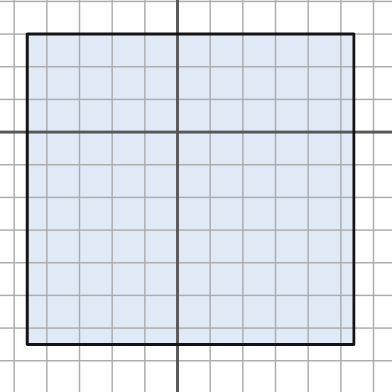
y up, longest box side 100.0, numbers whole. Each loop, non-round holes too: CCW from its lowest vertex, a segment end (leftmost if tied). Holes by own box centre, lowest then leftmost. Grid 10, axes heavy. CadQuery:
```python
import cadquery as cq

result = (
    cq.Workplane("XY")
    .moveTo(-46.0, -65.0)
    .lineTo(54.0, -65.0)
    .lineTo(54.0, 30.0)
    .lineTo(-46.0, 30.0)
    .close()
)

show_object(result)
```